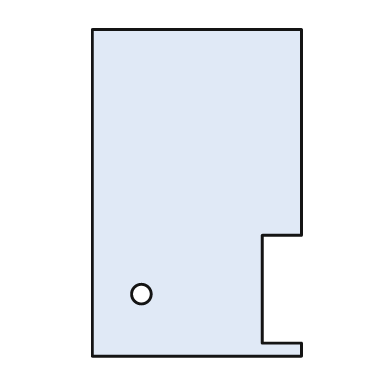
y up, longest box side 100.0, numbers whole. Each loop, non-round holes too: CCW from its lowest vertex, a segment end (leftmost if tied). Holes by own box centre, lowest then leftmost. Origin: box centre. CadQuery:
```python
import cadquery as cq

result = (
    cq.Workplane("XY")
    .moveTo(-32.0, -50.0)
    .lineTo(32.0, -50.0)
    .lineTo(32.0, -46.0)
    .lineTo(20.0, -46.0)
    .lineTo(20.0, -13.0)
    .lineTo(32.0, -13.0)
    .lineTo(32.0, 50.0)
    .lineTo(-32.0, 50.0)
    .close()
    .moveTo(-17.0, -31.0)
    .circle(3.0)
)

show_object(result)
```